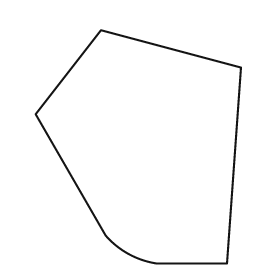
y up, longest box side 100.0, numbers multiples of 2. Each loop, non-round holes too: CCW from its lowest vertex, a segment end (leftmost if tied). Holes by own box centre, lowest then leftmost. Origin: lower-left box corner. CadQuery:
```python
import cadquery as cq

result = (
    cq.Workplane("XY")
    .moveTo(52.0, 0.0)
    .lineTo(82.0, 0.0)
    .lineTo(88.0, 84.0)
    .lineTo(28.0, 100.0)
    .lineTo(0.0, 64.0)
    .lineTo(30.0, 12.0)
    .threePointArc((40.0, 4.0), (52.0, 0.0))
    .close()
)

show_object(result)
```